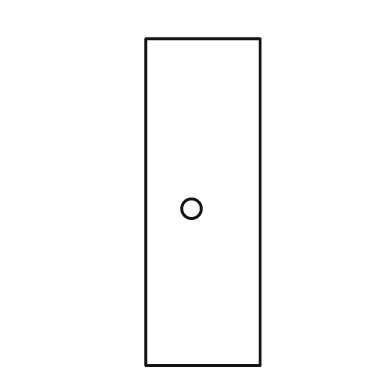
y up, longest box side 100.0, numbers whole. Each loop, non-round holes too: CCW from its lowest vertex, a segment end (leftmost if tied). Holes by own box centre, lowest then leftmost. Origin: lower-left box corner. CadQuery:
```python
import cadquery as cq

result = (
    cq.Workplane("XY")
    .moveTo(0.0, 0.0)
    .lineTo(35.0, 0.0)
    .lineTo(35.0, 100.0)
    .lineTo(0.0, 100.0)
    .close()
    .moveTo(14.0, 48.0)
    .circle(3.0)
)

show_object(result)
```